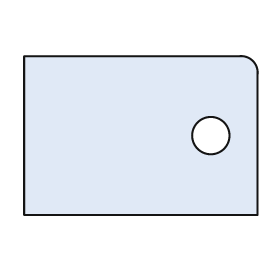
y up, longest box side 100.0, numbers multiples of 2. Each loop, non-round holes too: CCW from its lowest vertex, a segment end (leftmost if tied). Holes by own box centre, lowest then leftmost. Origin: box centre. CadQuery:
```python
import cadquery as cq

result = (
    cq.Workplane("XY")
    .moveTo(-50.0, -34.0)
    .lineTo(50.0, -34.0)
    .lineTo(50.0, 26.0)
    .threePointArc((48.0, 32.0), (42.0, 34.0))
    .lineTo(-50.0, 34.0)
    .close()
    .moveTo(30.0, 0.0)
    .circle(8.0)
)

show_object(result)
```